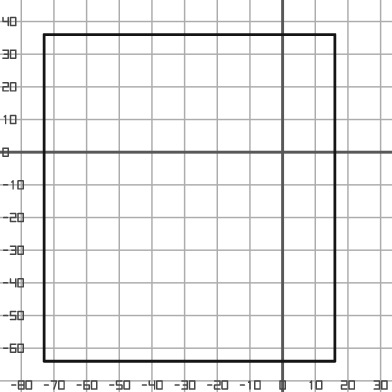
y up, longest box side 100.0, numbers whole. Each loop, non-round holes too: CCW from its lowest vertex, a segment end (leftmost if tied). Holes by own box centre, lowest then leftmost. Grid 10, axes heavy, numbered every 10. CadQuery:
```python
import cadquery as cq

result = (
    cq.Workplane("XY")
    .moveTo(-73.0, -64.0)
    .lineTo(16.0, -64.0)
    .lineTo(16.0, 36.0)
    .lineTo(-73.0, 36.0)
    .close()
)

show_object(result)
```